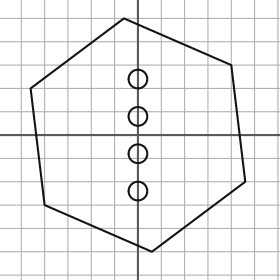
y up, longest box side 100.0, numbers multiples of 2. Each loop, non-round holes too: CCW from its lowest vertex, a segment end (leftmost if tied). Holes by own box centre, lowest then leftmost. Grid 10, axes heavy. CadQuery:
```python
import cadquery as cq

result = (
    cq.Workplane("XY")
    .moveTo(6.0, -50.0)
    .lineTo(46.0, -20.0)
    .lineTo(40.0, 30.0)
    .lineTo(-6.0, 50.0)
    .lineTo(-46.0, 20.0)
    .lineTo(-40.0, -30.0)
    .close()
    .moveTo(0.0, -24.0)
    .circle(4.0)
    .moveTo(0.0, -8.0)
    .circle(4.0)
    .moveTo(0.0, 8.0)
    .circle(4.0)
    .moveTo(0.0, 24.0)
    .circle(4.0)
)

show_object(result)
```